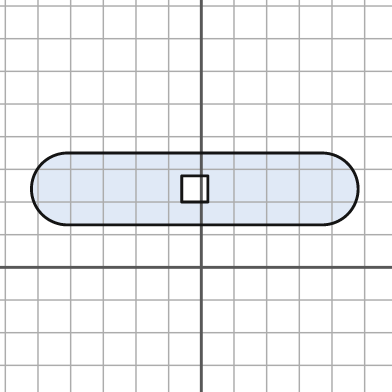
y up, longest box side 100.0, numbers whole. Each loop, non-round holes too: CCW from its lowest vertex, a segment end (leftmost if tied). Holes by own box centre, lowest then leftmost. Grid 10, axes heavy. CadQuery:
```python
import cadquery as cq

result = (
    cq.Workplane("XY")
    .moveTo(-41.0, 13.0)
    .lineTo(37.0, 13.0)
    .threePointArc((48.0, 24.0), (37.0, 35.0))
    .lineTo(-41.0, 35.0)
    .threePointArc((-52.0, 24.0), (-41.0, 13.0))
    .close()
    .moveTo(-6.0, 20.0)
    .lineTo(2.0, 20.0)
    .lineTo(2.0, 28.0)
    .lineTo(-6.0, 28.0)
    .close()
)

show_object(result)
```